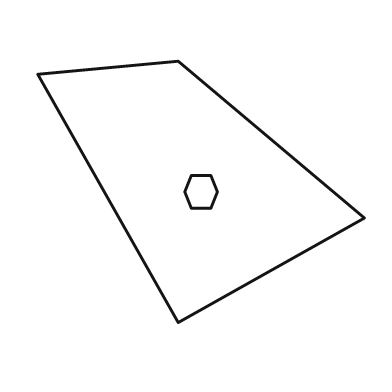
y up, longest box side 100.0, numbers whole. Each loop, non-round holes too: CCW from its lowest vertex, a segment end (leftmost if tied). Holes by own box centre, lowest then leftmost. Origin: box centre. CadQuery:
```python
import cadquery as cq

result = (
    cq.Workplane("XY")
    .moveTo(-7.0, -40.0)
    .lineTo(50.0, -8.0)
    .lineTo(-7.0, 40.0)
    .lineTo(-50.0, 36.0)
    .close()
    .moveTo(-3.0, -5.0)
    .lineTo(3.0, -5.0)
    .lineTo(5.0, 0.0)
    .lineTo(3.0, 5.0)
    .lineTo(-3.0, 5.0)
    .lineTo(-5.0, 0.0)
    .close()
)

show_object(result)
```